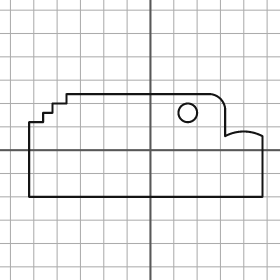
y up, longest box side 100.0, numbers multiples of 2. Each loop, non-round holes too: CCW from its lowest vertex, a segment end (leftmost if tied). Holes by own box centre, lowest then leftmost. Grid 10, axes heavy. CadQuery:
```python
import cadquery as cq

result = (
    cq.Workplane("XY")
    .moveTo(-52.0, -20.0)
    .lineTo(48.0, -20.0)
    .lineTo(48.0, 6.0)
    .threePointArc((40.0, 8.0), (32.0, 6.0))
    .lineTo(32.0, 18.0)
    .threePointArc((30.0, 22.0), (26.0, 24.0))
    .lineTo(-36.0, 24.0)
    .lineTo(-36.0, 20.0)
    .lineTo(-42.0, 20.0)
    .lineTo(-42.0, 16.0)
    .lineTo(-46.0, 16.0)
    .lineTo(-46.0, 12.0)
    .lineTo(-52.0, 12.0)
    .close()
    .moveTo(16.0, 16.0)
    .circle(4.0)
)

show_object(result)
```